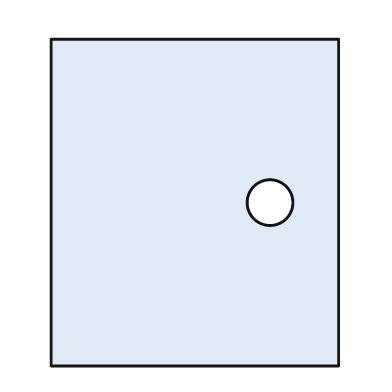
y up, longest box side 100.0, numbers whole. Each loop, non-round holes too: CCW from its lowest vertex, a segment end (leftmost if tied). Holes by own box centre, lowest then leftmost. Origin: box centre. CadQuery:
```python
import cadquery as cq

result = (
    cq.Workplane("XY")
    .moveTo(-44.0, -50.0)
    .lineTo(44.0, -50.0)
    .lineTo(44.0, 50.0)
    .lineTo(-44.0, 50.0)
    .close()
    .moveTo(23.0, 0.0)
    .circle(7.0)
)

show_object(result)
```